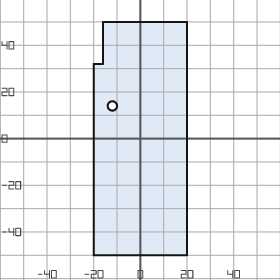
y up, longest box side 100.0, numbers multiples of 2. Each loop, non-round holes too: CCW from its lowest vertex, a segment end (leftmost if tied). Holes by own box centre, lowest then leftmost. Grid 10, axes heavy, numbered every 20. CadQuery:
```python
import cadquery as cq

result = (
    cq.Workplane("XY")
    .moveTo(-20.0, -50.0)
    .lineTo(20.0, -50.0)
    .lineTo(20.0, 50.0)
    .lineTo(-16.0, 50.0)
    .lineTo(-16.0, 32.0)
    .lineTo(-20.0, 32.0)
    .close()
    .moveTo(-12.0, 14.0)
    .circle(2.0)
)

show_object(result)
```